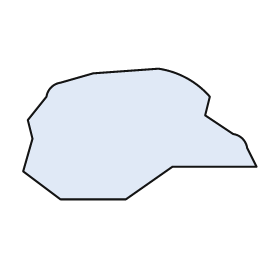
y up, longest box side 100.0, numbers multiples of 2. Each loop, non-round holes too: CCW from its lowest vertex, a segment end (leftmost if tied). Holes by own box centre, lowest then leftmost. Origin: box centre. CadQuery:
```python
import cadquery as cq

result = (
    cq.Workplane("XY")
    .moveTo(-34.0, -28.0)
    .lineTo(-6.0, -28.0)
    .lineTo(14.0, -14.0)
    .lineTo(50.0, -14.0)
    .lineTo(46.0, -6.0)
    .threePointArc((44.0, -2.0), (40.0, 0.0))
    .lineTo(28.0, 8.0)
    .lineTo(30.0, 16.0)
    .threePointArc((20.0, 24.0), (8.0, 28.0))
    .lineTo(-20.0, 26.0)
    .lineTo(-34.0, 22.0)
    .threePointArc((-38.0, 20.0), (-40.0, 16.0))
    .lineTo(-48.0, 6.0)
    .lineTo(-46.0, -2.0)
    .lineTo(-50.0, -16.0)
    .close()
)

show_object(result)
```